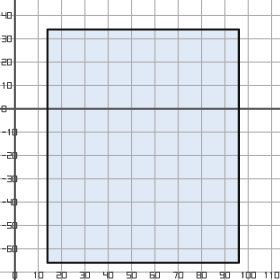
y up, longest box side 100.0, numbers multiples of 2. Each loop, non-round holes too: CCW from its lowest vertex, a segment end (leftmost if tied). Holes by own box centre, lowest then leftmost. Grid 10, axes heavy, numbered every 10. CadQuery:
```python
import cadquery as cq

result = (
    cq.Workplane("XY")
    .moveTo(14.0, -66.0)
    .lineTo(96.0, -66.0)
    .lineTo(96.0, 34.0)
    .lineTo(14.0, 34.0)
    .close()
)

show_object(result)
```